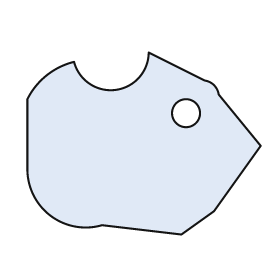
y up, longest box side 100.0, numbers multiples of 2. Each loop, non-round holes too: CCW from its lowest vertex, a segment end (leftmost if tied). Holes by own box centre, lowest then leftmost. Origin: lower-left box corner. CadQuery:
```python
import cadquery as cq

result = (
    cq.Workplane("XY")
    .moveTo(66.0, 0.0)
    .lineTo(80.0, 10.0)
    .lineTo(100.0, 38.0)
    .lineTo(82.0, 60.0)
    .threePointArc((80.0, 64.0), (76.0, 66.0))
    .lineTo(52.0, 78.0)
    .threePointArc((38.0, 62.0), (20.0, 74.0))
    .threePointArc((8.0, 68.0), (0.0, 58.0))
    .lineTo(0.0, 28.0)
    .threePointArc((10.0, 8.0), (32.0, 4.0))
    .close()
    .moveTo(68.0, 52.0)
    .circle(6.0)
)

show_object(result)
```